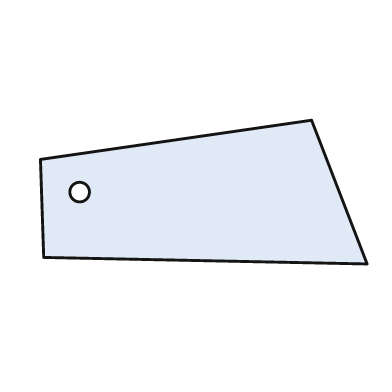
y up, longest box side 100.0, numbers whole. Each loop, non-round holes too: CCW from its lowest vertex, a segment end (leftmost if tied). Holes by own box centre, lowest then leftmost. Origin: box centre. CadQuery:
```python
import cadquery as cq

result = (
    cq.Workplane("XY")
    .moveTo(50.0, -22.0)
    .lineTo(33.0, 22.0)
    .lineTo(-50.0, 10.0)
    .lineTo(-49.0, -20.0)
    .close()
    .moveTo(-38.0, 0.0)
    .circle(3.0)
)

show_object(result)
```